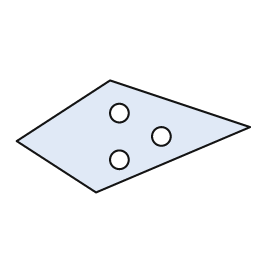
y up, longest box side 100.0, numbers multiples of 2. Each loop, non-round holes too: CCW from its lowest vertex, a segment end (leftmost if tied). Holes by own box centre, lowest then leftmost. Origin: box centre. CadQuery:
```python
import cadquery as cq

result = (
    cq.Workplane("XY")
    .moveTo(-16.0, -24.0)
    .lineTo(50.0, 4.0)
    .lineTo(-10.0, 24.0)
    .lineTo(-50.0, -2.0)
    .close()
    .moveTo(-6.0, -10.0)
    .circle(4.0)
    .moveTo(12.0, 0.0)
    .circle(4.0)
    .moveTo(-6.0, 10.0)
    .circle(4.0)
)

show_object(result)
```